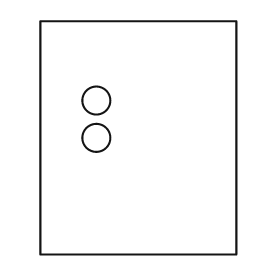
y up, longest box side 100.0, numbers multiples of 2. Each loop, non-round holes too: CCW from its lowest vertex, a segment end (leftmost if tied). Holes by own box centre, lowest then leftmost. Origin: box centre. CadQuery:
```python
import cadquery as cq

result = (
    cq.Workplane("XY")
    .moveTo(-42.0, -50.0)
    .lineTo(42.0, -50.0)
    .lineTo(42.0, 50.0)
    .lineTo(-42.0, 50.0)
    .close()
    .moveTo(-18.0, 0.0)
    .circle(6.0)
    .moveTo(-18.0, 16.0)
    .circle(6.0)
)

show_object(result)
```